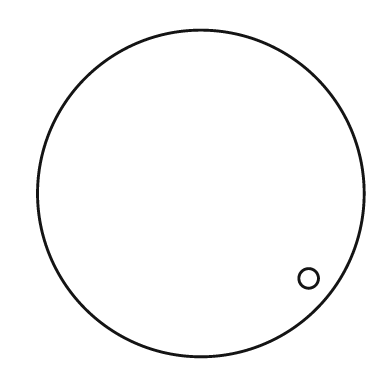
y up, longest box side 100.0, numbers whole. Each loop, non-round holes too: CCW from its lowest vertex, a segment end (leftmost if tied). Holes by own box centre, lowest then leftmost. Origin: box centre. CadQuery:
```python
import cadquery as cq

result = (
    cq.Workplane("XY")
    .moveTo(0.0, 0.0)
    .circle(50.0)
    .moveTo(33.0, -26.0)
    .circle(3.0)
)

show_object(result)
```